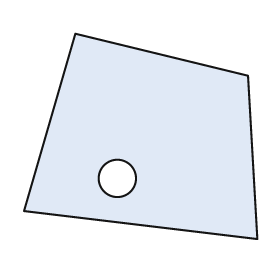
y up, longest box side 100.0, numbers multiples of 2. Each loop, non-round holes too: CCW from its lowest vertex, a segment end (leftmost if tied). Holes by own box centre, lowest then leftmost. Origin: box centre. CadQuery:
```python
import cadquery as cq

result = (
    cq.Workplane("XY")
    .moveTo(50.0, -44.0)
    .lineTo(46.0, 26.0)
    .lineTo(-28.0, 44.0)
    .lineTo(-50.0, -32.0)
    .close()
    .moveTo(-10.0, -18.0)
    .circle(8.0)
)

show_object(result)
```